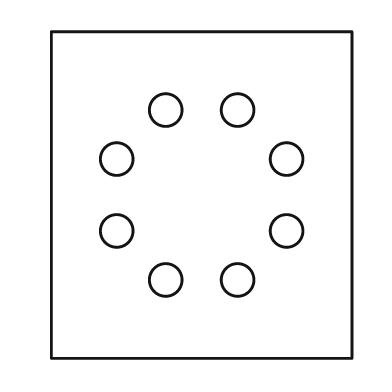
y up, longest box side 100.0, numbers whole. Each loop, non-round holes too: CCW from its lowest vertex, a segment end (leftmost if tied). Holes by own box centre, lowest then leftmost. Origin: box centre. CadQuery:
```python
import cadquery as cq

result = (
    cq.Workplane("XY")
    .moveTo(-46.0, -50.0)
    .lineTo(46.0, -50.0)
    .lineTo(46.0, 50.0)
    .lineTo(-46.0, 50.0)
    .close()
    .moveTo(-11.0, -26.0)
    .circle(5.0)
    .moveTo(11.0, -26.0)
    .circle(5.0)
    .moveTo(-26.0, -11.0)
    .circle(5.0)
    .moveTo(26.0, -11.0)
    .circle(5.0)
    .moveTo(-26.0, 11.0)
    .circle(5.0)
    .moveTo(26.0, 11.0)
    .circle(5.0)
    .moveTo(-11.0, 26.0)
    .circle(5.0)
    .moveTo(11.0, 26.0)
    .circle(5.0)
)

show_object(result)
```